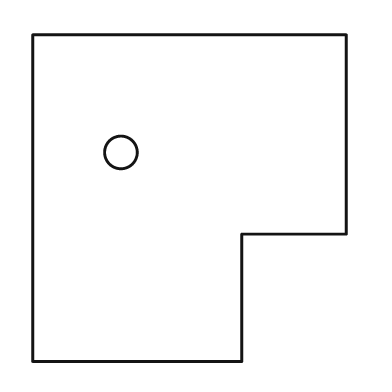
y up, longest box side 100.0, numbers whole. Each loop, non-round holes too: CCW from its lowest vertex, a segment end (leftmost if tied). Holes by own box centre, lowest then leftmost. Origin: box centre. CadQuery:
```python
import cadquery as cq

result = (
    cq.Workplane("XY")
    .moveTo(-48.0, -50.0)
    .lineTo(16.0, -50.0)
    .lineTo(16.0, -11.0)
    .lineTo(48.0, -11.0)
    .lineTo(48.0, 50.0)
    .lineTo(-48.0, 50.0)
    .close()
    .moveTo(-21.0, 14.0)
    .circle(5.0)
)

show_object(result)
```